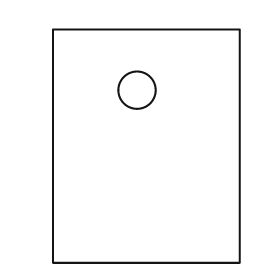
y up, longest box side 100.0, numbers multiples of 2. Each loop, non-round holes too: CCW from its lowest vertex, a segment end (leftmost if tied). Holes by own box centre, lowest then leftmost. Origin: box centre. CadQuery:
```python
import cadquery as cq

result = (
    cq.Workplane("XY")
    .moveTo(-40.0, -50.0)
    .lineTo(40.0, -50.0)
    .lineTo(40.0, 50.0)
    .lineTo(-40.0, 50.0)
    .close()
    .moveTo(-4.0, 24.0)
    .circle(8.0)
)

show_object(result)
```